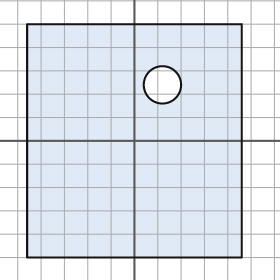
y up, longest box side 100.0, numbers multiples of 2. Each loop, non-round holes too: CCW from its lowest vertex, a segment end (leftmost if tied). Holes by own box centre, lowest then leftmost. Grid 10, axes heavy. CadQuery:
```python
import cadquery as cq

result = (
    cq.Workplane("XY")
    .moveTo(-46.0, -50.0)
    .lineTo(46.0, -50.0)
    .lineTo(46.0, 50.0)
    .lineTo(-46.0, 50.0)
    .close()
    .moveTo(12.0, 24.0)
    .circle(8.0)
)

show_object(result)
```